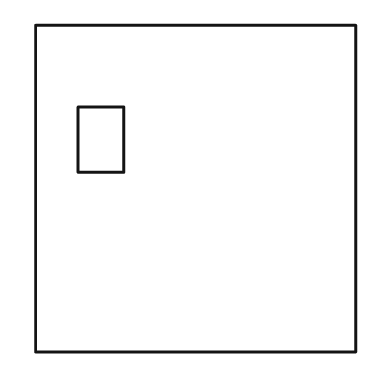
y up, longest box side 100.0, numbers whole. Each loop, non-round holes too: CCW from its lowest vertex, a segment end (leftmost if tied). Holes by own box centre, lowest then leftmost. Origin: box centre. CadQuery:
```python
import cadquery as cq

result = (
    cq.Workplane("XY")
    .moveTo(-49.0, -50.0)
    .lineTo(49.0, -50.0)
    .lineTo(49.0, 50.0)
    .lineTo(-49.0, 50.0)
    .close()
    .moveTo(-36.0, 5.0)
    .lineTo(-22.0, 5.0)
    .lineTo(-22.0, 25.0)
    .lineTo(-36.0, 25.0)
    .close()
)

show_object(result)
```